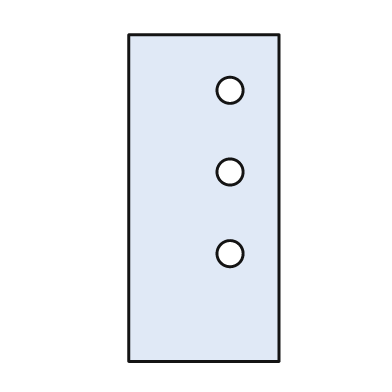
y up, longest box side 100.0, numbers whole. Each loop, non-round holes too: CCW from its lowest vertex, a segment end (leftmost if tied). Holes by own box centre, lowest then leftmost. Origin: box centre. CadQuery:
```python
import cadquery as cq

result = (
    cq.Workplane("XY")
    .moveTo(-23.0, -50.0)
    .lineTo(23.0, -50.0)
    .lineTo(23.0, 50.0)
    .lineTo(-23.0, 50.0)
    .close()
    .moveTo(8.0, -17.0)
    .circle(4.0)
    .moveTo(8.0, 8.0)
    .circle(4.0)
    .moveTo(8.0, 33.0)
    .circle(4.0)
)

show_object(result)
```